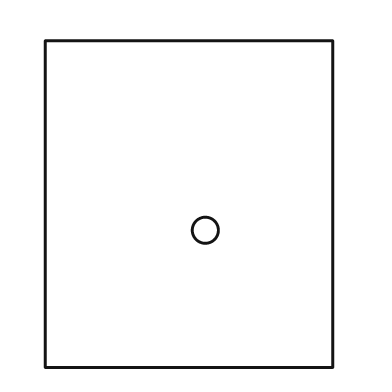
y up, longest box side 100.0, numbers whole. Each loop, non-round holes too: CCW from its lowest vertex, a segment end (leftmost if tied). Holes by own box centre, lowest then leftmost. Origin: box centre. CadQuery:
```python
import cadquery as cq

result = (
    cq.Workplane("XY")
    .moveTo(-44.0, -50.0)
    .lineTo(44.0, -50.0)
    .lineTo(44.0, 50.0)
    .lineTo(-44.0, 50.0)
    .close()
    .moveTo(5.0, -8.0)
    .circle(4.0)
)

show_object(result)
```